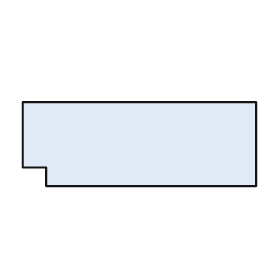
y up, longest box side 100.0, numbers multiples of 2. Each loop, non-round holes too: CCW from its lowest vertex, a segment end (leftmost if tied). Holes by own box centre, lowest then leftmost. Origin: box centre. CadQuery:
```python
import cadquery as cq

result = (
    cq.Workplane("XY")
    .moveTo(-40.0, -18.0)
    .lineTo(50.0, -18.0)
    .lineTo(50.0, 18.0)
    .lineTo(-50.0, 18.0)
    .lineTo(-50.0, -10.0)
    .lineTo(-40.0, -10.0)
    .close()
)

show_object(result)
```